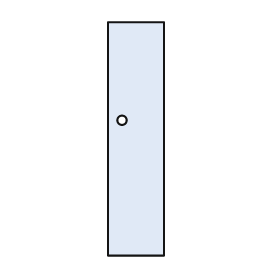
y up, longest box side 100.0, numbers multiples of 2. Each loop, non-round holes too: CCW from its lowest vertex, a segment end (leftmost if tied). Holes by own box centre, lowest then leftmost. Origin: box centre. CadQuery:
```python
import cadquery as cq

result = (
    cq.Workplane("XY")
    .moveTo(-12.0, -50.0)
    .lineTo(12.0, -50.0)
    .lineTo(12.0, 50.0)
    .lineTo(-12.0, 50.0)
    .close()
    .moveTo(-6.0, 8.0)
    .circle(2.0)
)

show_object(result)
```